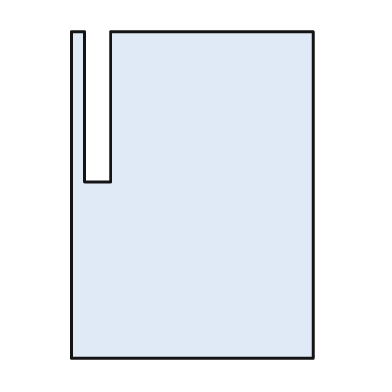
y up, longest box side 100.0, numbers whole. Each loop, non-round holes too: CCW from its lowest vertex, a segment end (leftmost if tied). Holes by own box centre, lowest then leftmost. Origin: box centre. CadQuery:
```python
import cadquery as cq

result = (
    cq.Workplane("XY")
    .moveTo(-37.0, -50.0)
    .lineTo(37.0, -50.0)
    .lineTo(37.0, 50.0)
    .lineTo(-25.0, 50.0)
    .lineTo(-25.0, 4.0)
    .lineTo(-33.0, 4.0)
    .lineTo(-33.0, 50.0)
    .lineTo(-37.0, 50.0)
    .close()
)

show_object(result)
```